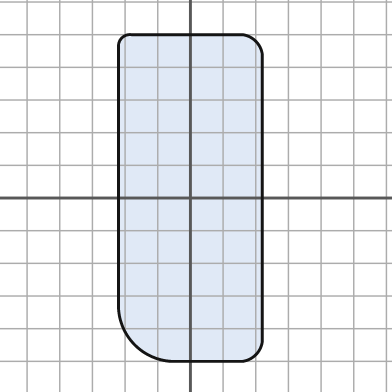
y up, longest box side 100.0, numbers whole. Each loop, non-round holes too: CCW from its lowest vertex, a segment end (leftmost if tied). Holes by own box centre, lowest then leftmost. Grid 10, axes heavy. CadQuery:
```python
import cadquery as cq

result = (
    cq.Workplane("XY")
    .moveTo(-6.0, -50.0)
    .lineTo(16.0, -50.0)
    .threePointArc((20.0, -48.0), (22.0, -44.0))
    .lineTo(22.0, 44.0)
    .threePointArc((20.0, 48.0), (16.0, 50.0))
    .lineTo(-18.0, 50.0)
    .threePointArc((-21.0, 49.0), (-22.0, 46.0))
    .lineTo(-22.0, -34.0)
    .threePointArc((-17.0, -45.0), (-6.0, -50.0))
    .close()
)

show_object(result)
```